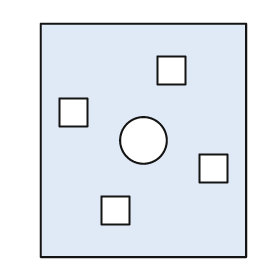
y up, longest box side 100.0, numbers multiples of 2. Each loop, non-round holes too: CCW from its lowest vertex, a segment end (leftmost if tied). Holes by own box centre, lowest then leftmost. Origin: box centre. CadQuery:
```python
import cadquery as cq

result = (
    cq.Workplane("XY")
    .moveTo(-44.0, -50.0)
    .lineTo(44.0, -50.0)
    .lineTo(44.0, 50.0)
    .lineTo(-44.0, 50.0)
    .close()
    .moveTo(-18.0, -36.0)
    .lineTo(-6.0, -36.0)
    .lineTo(-6.0, -24.0)
    .lineTo(-18.0, -24.0)
    .close()
    .moveTo(24.0, -18.0)
    .lineTo(36.0, -18.0)
    .lineTo(36.0, -6.0)
    .lineTo(24.0, -6.0)
    .close()
    .moveTo(0.0, 0.0)
    .circle(10.0)
    .moveTo(-36.0, 6.0)
    .lineTo(-24.0, 6.0)
    .lineTo(-24.0, 18.0)
    .lineTo(-36.0, 18.0)
    .close()
    .moveTo(6.0, 24.0)
    .lineTo(18.0, 24.0)
    .lineTo(18.0, 36.0)
    .lineTo(6.0, 36.0)
    .close()
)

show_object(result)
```